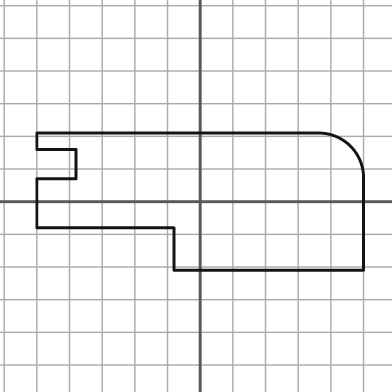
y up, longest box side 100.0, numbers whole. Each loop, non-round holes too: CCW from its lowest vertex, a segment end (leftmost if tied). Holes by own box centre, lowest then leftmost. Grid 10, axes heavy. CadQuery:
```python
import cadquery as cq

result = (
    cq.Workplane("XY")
    .moveTo(-8.0, -21.0)
    .lineTo(50.0, -21.0)
    .lineTo(50.0, 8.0)
    .threePointArc((46.0, 17.0), (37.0, 21.0))
    .lineTo(-50.0, 21.0)
    .lineTo(-50.0, 16.0)
    .lineTo(-38.0, 16.0)
    .lineTo(-38.0, 7.0)
    .lineTo(-50.0, 7.0)
    .lineTo(-50.0, -8.0)
    .lineTo(-8.0, -8.0)
    .close()
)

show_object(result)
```